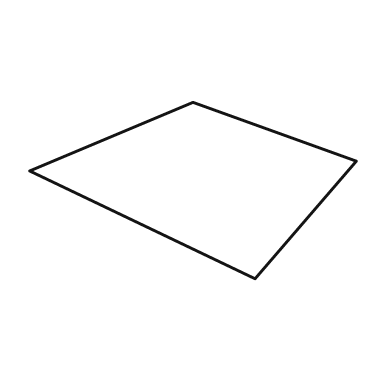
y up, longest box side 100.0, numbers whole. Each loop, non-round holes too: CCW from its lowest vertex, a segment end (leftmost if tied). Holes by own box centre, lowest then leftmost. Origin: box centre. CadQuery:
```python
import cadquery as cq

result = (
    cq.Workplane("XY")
    .moveTo(19.0, -27.0)
    .lineTo(50.0, 9.0)
    .lineTo(0.0, 27.0)
    .lineTo(-50.0, 6.0)
    .close()
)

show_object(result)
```